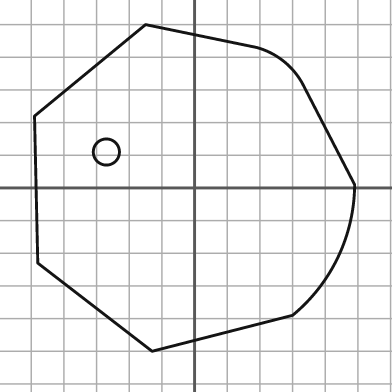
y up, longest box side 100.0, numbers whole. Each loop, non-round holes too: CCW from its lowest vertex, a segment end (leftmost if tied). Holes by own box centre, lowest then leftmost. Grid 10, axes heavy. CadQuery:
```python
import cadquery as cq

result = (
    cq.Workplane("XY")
    .moveTo(-13.0, -50.0)
    .lineTo(30.0, -39.0)
    .threePointArc((44.0, -21.0), (49.0, 1.0))
    .lineTo(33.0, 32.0)
    .threePointArc((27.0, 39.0), (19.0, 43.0))
    .lineTo(-15.0, 50.0)
    .lineTo(-49.0, 22.0)
    .lineTo(-48.0, -23.0)
    .close()
    .moveTo(-27.0, 11.0)
    .circle(4.0)
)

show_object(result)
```